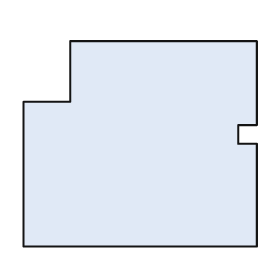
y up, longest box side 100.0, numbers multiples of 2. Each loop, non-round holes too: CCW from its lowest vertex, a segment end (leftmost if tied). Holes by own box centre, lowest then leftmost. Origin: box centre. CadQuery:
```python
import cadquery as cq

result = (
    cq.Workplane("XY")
    .moveTo(-50.0, -44.0)
    .lineTo(50.0, -44.0)
    .lineTo(50.0, 0.0)
    .lineTo(42.0, 0.0)
    .lineTo(42.0, 8.0)
    .lineTo(50.0, 8.0)
    .lineTo(50.0, 44.0)
    .lineTo(-30.0, 44.0)
    .lineTo(-30.0, 18.0)
    .lineTo(-50.0, 18.0)
    .close()
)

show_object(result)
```